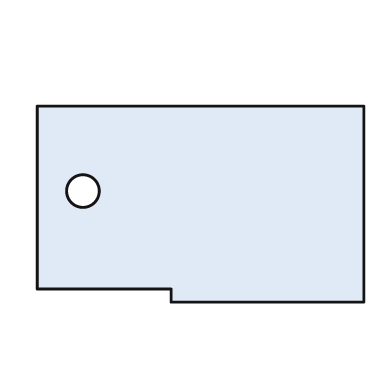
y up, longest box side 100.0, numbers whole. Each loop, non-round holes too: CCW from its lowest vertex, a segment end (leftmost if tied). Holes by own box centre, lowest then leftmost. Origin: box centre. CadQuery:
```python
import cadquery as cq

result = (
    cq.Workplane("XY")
    .moveTo(-9.0, -30.0)
    .lineTo(50.0, -30.0)
    .lineTo(50.0, 30.0)
    .lineTo(-50.0, 30.0)
    .lineTo(-50.0, -26.0)
    .lineTo(-9.0, -26.0)
    .close()
    .moveTo(-36.0, 4.0)
    .circle(5.0)
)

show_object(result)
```